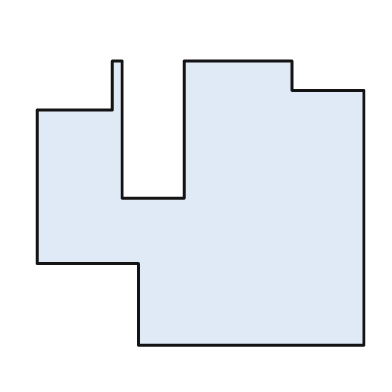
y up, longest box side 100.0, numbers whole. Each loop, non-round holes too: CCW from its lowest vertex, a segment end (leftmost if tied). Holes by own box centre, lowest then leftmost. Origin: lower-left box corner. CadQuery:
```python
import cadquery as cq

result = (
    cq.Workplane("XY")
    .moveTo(31.0, 0.0)
    .lineTo(100.0, 0.0)
    .lineTo(100.0, 78.0)
    .lineTo(78.0, 78.0)
    .lineTo(78.0, 87.0)
    .lineTo(45.0, 87.0)
    .lineTo(45.0, 45.0)
    .lineTo(26.0, 45.0)
    .lineTo(26.0, 87.0)
    .lineTo(23.0, 87.0)
    .lineTo(23.0, 72.0)
    .lineTo(0.0, 72.0)
    .lineTo(0.0, 25.0)
    .lineTo(31.0, 25.0)
    .close()
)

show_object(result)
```